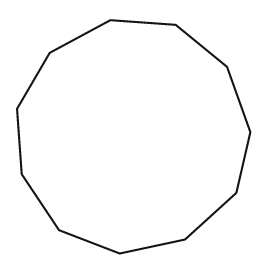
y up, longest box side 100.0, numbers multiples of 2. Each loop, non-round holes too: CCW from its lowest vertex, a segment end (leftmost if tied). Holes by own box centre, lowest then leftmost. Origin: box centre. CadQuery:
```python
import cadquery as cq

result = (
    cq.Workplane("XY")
    .moveTo(-6.0, -50.0)
    .lineTo(22.0, -44.0)
    .lineTo(44.0, -24.0)
    .lineTo(50.0, 2.0)
    .lineTo(40.0, 30.0)
    .lineTo(18.0, 48.0)
    .lineTo(-10.0, 50.0)
    .lineTo(-36.0, 36.0)
    .lineTo(-50.0, 12.0)
    .lineTo(-48.0, -16.0)
    .lineTo(-32.0, -40.0)
    .close()
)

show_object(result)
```